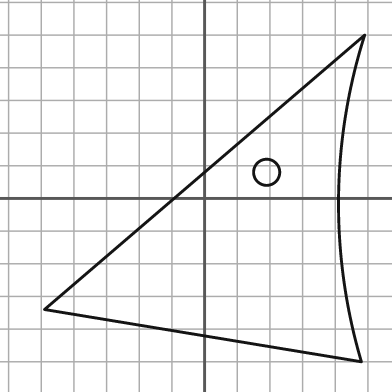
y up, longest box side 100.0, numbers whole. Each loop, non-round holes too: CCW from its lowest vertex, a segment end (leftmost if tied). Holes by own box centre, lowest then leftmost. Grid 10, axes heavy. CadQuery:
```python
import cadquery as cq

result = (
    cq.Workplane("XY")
    .moveTo(48.0, -50.0)
    .threePointArc((41.0, 0.0), (49.0, 50.0))
    .lineTo(-49.0, -34.0)
    .close()
    .moveTo(19.0, 8.0)
    .circle(4.0)
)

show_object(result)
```